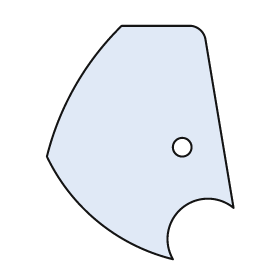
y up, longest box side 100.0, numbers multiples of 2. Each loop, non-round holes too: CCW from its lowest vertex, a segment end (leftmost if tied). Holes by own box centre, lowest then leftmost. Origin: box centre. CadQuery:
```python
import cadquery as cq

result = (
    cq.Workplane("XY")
    .moveTo(14.0, -50.0)
    .threePointArc((18.0, -28.0), (40.0, -28.0))
    .lineTo(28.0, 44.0)
    .threePointArc((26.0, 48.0), (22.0, 50.0))
    .lineTo(-8.0, 50.0)
    .threePointArc((-28.0, 24.0), (-40.0, -6.0))
    .threePointArc((-18.0, -34.0), (14.0, -50.0))
    .close()
    .moveTo(18.0, -2.0)
    .circle(4.0)
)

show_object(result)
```